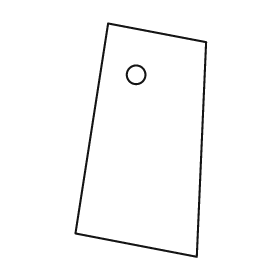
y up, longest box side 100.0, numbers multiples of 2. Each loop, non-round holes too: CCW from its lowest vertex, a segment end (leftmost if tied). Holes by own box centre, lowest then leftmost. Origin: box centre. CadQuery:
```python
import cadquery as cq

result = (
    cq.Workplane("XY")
    .moveTo(24.0, -50.0)
    .lineTo(28.0, 42.0)
    .lineTo(-14.0, 50.0)
    .lineTo(-28.0, -40.0)
    .close()
    .moveTo(-2.0, 28.0)
    .circle(4.0)
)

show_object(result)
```